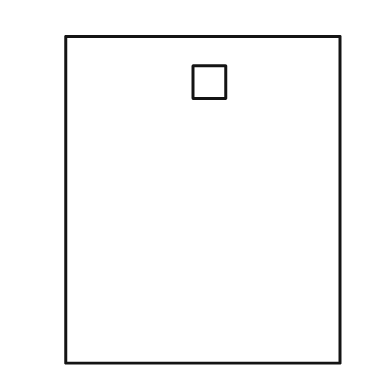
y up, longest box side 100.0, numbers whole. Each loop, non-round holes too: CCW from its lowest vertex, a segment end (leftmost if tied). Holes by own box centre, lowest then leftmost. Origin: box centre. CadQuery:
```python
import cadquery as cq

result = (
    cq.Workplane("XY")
    .moveTo(-42.0, -50.0)
    .lineTo(42.0, -50.0)
    .lineTo(42.0, 50.0)
    .lineTo(-42.0, 50.0)
    .close()
    .moveTo(-3.0, 31.0)
    .lineTo(7.0, 31.0)
    .lineTo(7.0, 41.0)
    .lineTo(-3.0, 41.0)
    .close()
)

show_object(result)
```